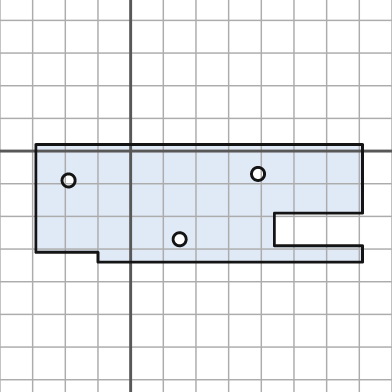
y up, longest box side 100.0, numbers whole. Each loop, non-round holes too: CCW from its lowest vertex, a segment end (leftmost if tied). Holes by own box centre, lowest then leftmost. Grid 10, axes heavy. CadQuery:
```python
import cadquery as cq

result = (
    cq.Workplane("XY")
    .moveTo(-10.0, -34.0)
    .lineTo(71.0, -34.0)
    .lineTo(71.0, -29.0)
    .lineTo(44.0, -29.0)
    .lineTo(44.0, -19.0)
    .lineTo(71.0, -19.0)
    .lineTo(71.0, 2.0)
    .lineTo(-29.0, 2.0)
    .lineTo(-29.0, -31.0)
    .lineTo(-10.0, -31.0)
    .close()
    .moveTo(15.0, -27.0)
    .circle(2.0)
    .moveTo(-19.0, -9.0)
    .circle(2.0)
    .moveTo(39.0, -7.0)
    .circle(2.0)
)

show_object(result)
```